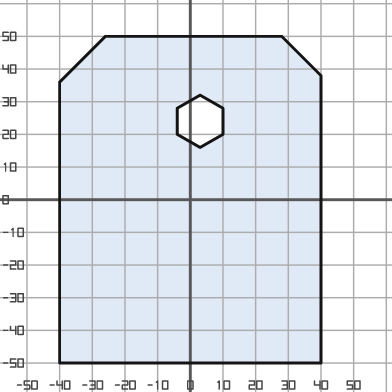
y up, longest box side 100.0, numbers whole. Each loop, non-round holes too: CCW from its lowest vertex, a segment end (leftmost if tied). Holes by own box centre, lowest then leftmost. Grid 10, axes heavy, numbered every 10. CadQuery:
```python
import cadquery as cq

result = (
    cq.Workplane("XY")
    .moveTo(-40.0, -50.0)
    .lineTo(40.0, -50.0)
    .lineTo(40.0, 38.0)
    .lineTo(28.0, 50.0)
    .lineTo(-26.0, 50.0)
    .lineTo(-40.0, 36.0)
    .close()
    .moveTo(3.0, 16.0)
    .lineTo(10.0, 20.0)
    .lineTo(10.0, 28.0)
    .lineTo(3.0, 32.0)
    .lineTo(-4.0, 28.0)
    .lineTo(-4.0, 20.0)
    .close()
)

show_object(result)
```